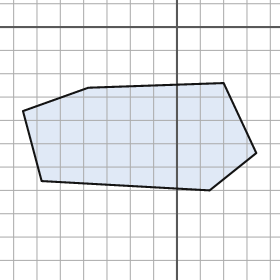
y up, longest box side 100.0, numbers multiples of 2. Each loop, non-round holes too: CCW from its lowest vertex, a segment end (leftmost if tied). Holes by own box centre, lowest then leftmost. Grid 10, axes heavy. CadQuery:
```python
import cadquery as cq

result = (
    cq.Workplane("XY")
    .moveTo(14.0, -70.0)
    .lineTo(34.0, -54.0)
    .lineTo(20.0, -24.0)
    .lineTo(-38.0, -26.0)
    .lineTo(-66.0, -36.0)
    .lineTo(-58.0, -66.0)
    .close()
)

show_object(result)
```